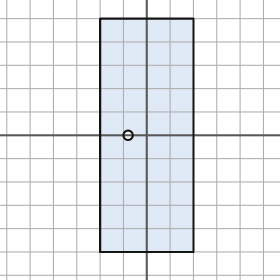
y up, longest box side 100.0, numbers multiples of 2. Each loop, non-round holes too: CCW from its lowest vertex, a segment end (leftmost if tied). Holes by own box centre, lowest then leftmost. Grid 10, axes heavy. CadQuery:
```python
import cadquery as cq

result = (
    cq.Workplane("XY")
    .moveTo(-20.0, -50.0)
    .lineTo(20.0, -50.0)
    .lineTo(20.0, 50.0)
    .lineTo(-20.0, 50.0)
    .close()
    .moveTo(-8.0, 0.0)
    .circle(2.0)
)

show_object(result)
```